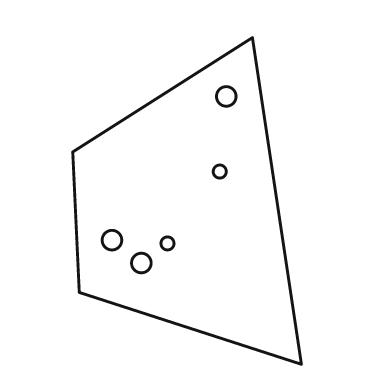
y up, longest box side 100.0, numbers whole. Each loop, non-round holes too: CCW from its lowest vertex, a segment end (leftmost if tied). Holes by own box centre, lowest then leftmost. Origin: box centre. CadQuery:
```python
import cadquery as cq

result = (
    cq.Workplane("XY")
    .moveTo(35.0, -50.0)
    .lineTo(20.0, 50.0)
    .lineTo(-35.0, 15.0)
    .lineTo(-33.0, -28.0)
    .close()
    .moveTo(-14.0, -19.0)
    .circle(3.0)
    .moveTo(-6.0, -13.0)
    .circle(2.0)
    .moveTo(-23.0, -12.0)
    .circle(3.0)
    .moveTo(10.0, 9.0)
    .circle(2.0)
    .moveTo(12.0, 32.0)
    .circle(3.0)
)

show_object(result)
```